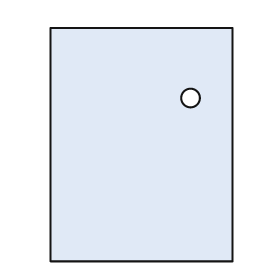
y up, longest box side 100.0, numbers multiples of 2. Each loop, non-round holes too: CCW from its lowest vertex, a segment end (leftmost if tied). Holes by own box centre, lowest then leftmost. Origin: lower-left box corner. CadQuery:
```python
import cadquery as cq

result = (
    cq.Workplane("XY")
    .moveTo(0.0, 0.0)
    .lineTo(78.0, 0.0)
    .lineTo(78.0, 100.0)
    .lineTo(0.0, 100.0)
    .close()
    .moveTo(60.0, 70.0)
    .circle(4.0)
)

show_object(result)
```